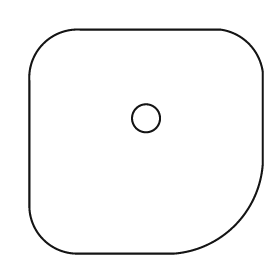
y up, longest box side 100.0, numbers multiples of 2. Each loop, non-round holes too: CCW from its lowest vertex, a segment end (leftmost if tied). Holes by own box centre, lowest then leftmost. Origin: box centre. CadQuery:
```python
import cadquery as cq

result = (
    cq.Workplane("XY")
    .moveTo(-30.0, -48.0)
    .lineTo(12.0, -48.0)
    .threePointArc((38.0, -36.0), (50.0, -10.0))
    .lineTo(50.0, 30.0)
    .threePointArc((44.0, 42.0), (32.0, 48.0))
    .lineTo(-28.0, 48.0)
    .threePointArc((-44.0, 42.0), (-50.0, 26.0))
    .lineTo(-50.0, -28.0)
    .threePointArc((-44.0, -42.0), (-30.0, -48.0))
    .close()
    .moveTo(0.0, 10.0)
    .circle(6.0)
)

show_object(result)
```